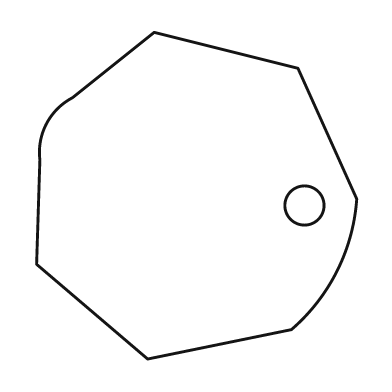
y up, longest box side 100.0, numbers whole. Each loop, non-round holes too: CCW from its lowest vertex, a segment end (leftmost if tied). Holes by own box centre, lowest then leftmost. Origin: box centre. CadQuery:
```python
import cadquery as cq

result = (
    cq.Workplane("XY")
    .moveTo(-15.0, -50.0)
    .lineTo(29.0, -41.0)
    .threePointArc((43.0, -23.0), (49.0, -1.0))
    .lineTo(31.0, 39.0)
    .lineTo(-13.0, 50.0)
    .lineTo(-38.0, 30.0)
    .threePointArc((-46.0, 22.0), (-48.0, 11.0))
    .lineTo(-49.0, -21.0)
    .close()
    .moveTo(33.0, -3.0)
    .circle(6.0)
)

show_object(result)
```